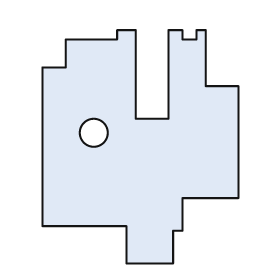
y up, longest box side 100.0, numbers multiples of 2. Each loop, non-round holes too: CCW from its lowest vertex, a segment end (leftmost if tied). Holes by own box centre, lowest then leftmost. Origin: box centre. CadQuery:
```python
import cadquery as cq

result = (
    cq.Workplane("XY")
    .moveTo(-6.0, -50.0)
    .lineTo(14.0, -50.0)
    .lineTo(14.0, -36.0)
    .lineTo(18.0, -36.0)
    .lineTo(18.0, -22.0)
    .lineTo(42.0, -22.0)
    .lineTo(42.0, 26.0)
    .lineTo(28.0, 26.0)
    .lineTo(28.0, 50.0)
    .lineTo(24.0, 50.0)
    .lineTo(24.0, 46.0)
    .lineTo(18.0, 46.0)
    .lineTo(18.0, 50.0)
    .lineTo(12.0, 50.0)
    .lineTo(12.0, 12.0)
    .lineTo(-2.0, 12.0)
    .lineTo(-2.0, 50.0)
    .lineTo(-10.0, 50.0)
    .lineTo(-10.0, 46.0)
    .lineTo(-32.0, 46.0)
    .lineTo(-32.0, 34.0)
    .lineTo(-42.0, 34.0)
    .lineTo(-42.0, -34.0)
    .lineTo(-6.0, -34.0)
    .close()
    .moveTo(-20.0, 6.0)
    .circle(6.0)
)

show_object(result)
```